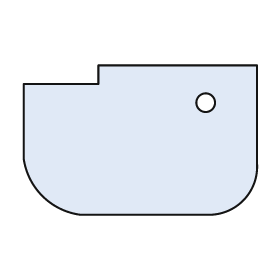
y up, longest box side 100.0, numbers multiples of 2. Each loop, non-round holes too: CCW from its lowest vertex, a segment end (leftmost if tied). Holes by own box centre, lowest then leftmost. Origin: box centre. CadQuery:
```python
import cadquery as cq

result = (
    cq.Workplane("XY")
    .moveTo(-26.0, -32.0)
    .lineTo(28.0, -32.0)
    .threePointArc((44.0, -26.0), (50.0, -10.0))
    .lineTo(50.0, 32.0)
    .lineTo(-18.0, 32.0)
    .lineTo(-18.0, 24.0)
    .lineTo(-50.0, 24.0)
    .lineTo(-50.0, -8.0)
    .threePointArc((-42.0, -24.0), (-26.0, -32.0))
    .close()
    .moveTo(28.0, 16.0)
    .circle(4.0)
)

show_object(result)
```